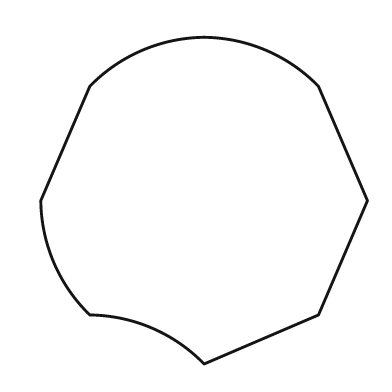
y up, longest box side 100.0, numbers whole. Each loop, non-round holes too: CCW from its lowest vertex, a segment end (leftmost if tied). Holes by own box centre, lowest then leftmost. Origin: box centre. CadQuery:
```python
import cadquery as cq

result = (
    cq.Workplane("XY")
    .moveTo(0.0, -50.0)
    .lineTo(35.0, -35.0)
    .lineTo(50.0, 0.0)
    .lineTo(35.0, 35.0)
    .threePointArc((19.0, 46.0), (0.0, 50.0))
    .threePointArc((-19.0, 46.0), (-35.0, 35.0))
    .lineTo(-50.0, 0.0)
    .threePointArc((-46.0, -19.0), (-35.0, -35.0))
    .threePointArc((-16.0, -39.0), (0.0, -50.0))
    .close()
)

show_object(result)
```